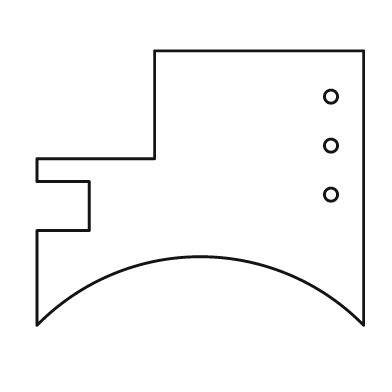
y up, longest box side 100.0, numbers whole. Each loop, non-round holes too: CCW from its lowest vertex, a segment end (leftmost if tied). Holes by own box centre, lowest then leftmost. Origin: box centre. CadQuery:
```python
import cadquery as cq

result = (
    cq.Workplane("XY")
    .moveTo(-50.0, -42.0)
    .threePointArc((0.0, -21.0), (50.0, -42.0))
    .lineTo(50.0, 42.0)
    .lineTo(-14.0, 42.0)
    .lineTo(-14.0, 9.0)
    .lineTo(-50.0, 9.0)
    .lineTo(-50.0, 2.0)
    .lineTo(-34.0, 2.0)
    .lineTo(-34.0, -13.0)
    .lineTo(-50.0, -13.0)
    .close()
    .moveTo(40.0, -2.0)
    .circle(2.0)
    .moveTo(40.0, 13.0)
    .circle(2.0)
    .moveTo(40.0, 28.0)
    .circle(2.0)
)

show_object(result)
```